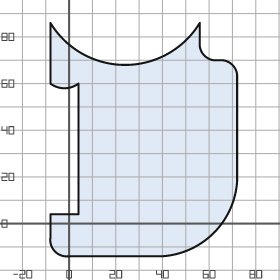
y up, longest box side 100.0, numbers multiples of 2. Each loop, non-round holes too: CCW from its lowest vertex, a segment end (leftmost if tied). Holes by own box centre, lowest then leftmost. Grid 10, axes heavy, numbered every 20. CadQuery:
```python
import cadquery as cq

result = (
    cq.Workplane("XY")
    .moveTo(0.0, -14.0)
    .lineTo(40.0, -14.0)
    .threePointArc((62.0, -4.0), (72.0, 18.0))
    .lineTo(72.0, 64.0)
    .threePointArc((70.0, 68.0), (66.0, 70.0))
    .lineTo(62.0, 70.0)
    .threePointArc((58.0, 72.0), (56.0, 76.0))
    .lineTo(56.0, 86.0)
    .threePointArc((24.0, 68.0), (-8.0, 86.0))
    .lineTo(-8.0, 60.0)
    .threePointArc((-2.0, 58.0), (4.0, 60.0))
    .lineTo(4.0, 4.0)
    .lineTo(-8.0, 4.0)
    .lineTo(-8.0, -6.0)
    .threePointArc((-6.0, -12.0), (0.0, -14.0))
    .close()
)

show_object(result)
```